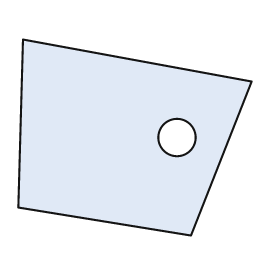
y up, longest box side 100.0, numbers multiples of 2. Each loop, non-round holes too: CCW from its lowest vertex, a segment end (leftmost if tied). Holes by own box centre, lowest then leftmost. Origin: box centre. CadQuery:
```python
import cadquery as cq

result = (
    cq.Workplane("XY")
    .moveTo(24.0, -42.0)
    .lineTo(50.0, 24.0)
    .lineTo(-48.0, 42.0)
    .lineTo(-50.0, -30.0)
    .close()
    .moveTo(18.0, 0.0)
    .circle(8.0)
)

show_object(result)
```